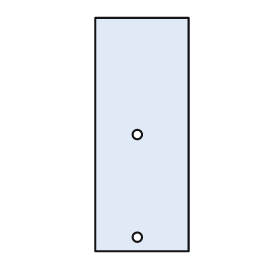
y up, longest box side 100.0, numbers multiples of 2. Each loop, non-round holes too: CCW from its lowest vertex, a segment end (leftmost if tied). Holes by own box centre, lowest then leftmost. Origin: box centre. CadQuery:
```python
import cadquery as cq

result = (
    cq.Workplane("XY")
    .moveTo(-20.0, -50.0)
    .lineTo(20.0, -50.0)
    .lineTo(20.0, 50.0)
    .lineTo(-20.0, 50.0)
    .close()
    .moveTo(-2.0, -44.0)
    .circle(2.0)
    .moveTo(-2.0, 0.0)
    .circle(2.0)
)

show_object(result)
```